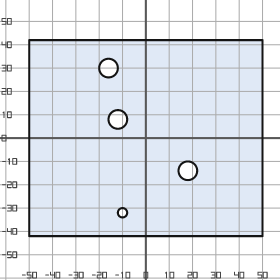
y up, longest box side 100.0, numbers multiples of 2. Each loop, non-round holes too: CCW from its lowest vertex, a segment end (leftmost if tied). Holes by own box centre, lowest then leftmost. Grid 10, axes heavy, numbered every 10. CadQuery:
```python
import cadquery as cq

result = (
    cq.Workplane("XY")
    .moveTo(-50.0, -42.0)
    .lineTo(50.0, -42.0)
    .lineTo(50.0, 42.0)
    .lineTo(-50.0, 42.0)
    .close()
    .moveTo(-10.0, -32.0)
    .circle(2.0)
    .moveTo(18.0, -14.0)
    .circle(4.0)
    .moveTo(-12.0, 8.0)
    .circle(4.0)
    .moveTo(-16.0, 30.0)
    .circle(4.0)
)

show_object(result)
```